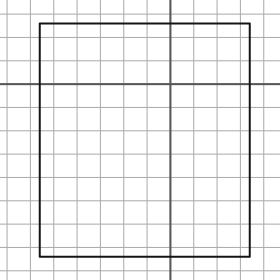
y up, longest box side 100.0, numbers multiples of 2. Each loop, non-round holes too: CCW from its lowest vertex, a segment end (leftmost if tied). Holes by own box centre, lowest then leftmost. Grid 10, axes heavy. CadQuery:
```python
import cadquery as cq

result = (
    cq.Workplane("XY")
    .moveTo(-56.0, -74.0)
    .lineTo(34.0, -74.0)
    .lineTo(34.0, 26.0)
    .lineTo(-56.0, 26.0)
    .close()
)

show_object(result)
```